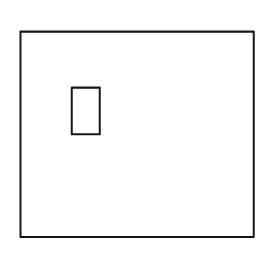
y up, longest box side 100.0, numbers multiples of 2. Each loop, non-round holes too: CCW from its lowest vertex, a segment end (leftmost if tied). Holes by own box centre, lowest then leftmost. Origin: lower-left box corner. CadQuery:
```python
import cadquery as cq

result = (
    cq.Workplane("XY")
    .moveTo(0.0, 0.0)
    .lineTo(100.0, 0.0)
    .lineTo(100.0, 88.0)
    .lineTo(0.0, 88.0)
    .close()
    .moveTo(22.0, 44.0)
    .lineTo(34.0, 44.0)
    .lineTo(34.0, 64.0)
    .lineTo(22.0, 64.0)
    .close()
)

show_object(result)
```